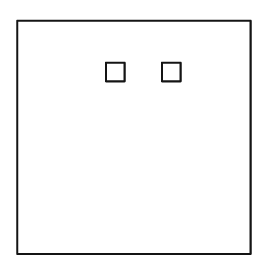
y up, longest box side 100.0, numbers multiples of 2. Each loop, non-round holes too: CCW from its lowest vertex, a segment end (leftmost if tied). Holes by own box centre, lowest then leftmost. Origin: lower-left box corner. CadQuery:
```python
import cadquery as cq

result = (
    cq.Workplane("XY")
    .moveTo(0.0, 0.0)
    .lineTo(100.0, 0.0)
    .lineTo(100.0, 100.0)
    .lineTo(0.0, 100.0)
    .close()
    .moveTo(38.0, 74.0)
    .lineTo(46.0, 74.0)
    .lineTo(46.0, 82.0)
    .lineTo(38.0, 82.0)
    .close()
    .moveTo(62.0, 74.0)
    .lineTo(70.0, 74.0)
    .lineTo(70.0, 82.0)
    .lineTo(62.0, 82.0)
    .close()
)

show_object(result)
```